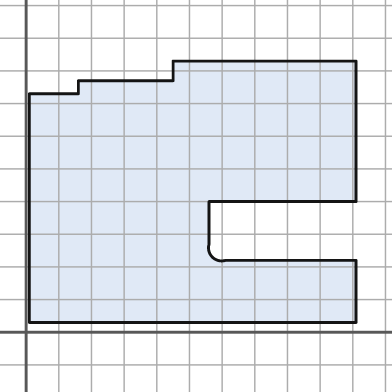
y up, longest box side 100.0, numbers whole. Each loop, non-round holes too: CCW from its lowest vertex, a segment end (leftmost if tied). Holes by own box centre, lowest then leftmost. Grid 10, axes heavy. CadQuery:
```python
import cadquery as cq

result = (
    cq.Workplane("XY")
    .moveTo(1.0, 3.0)
    .lineTo(101.0, 3.0)
    .lineTo(101.0, 22.0)
    .lineTo(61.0, 22.0)
    .threePointArc((57.0, 23.0), (56.0, 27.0))
    .lineTo(56.0, 40.0)
    .lineTo(101.0, 40.0)
    .lineTo(101.0, 83.0)
    .lineTo(45.0, 83.0)
    .lineTo(45.0, 77.0)
    .lineTo(16.0, 77.0)
    .lineTo(16.0, 73.0)
    .lineTo(1.0, 73.0)
    .close()
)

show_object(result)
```